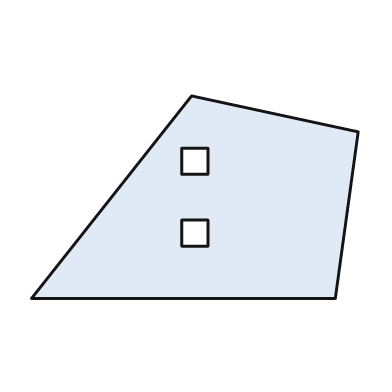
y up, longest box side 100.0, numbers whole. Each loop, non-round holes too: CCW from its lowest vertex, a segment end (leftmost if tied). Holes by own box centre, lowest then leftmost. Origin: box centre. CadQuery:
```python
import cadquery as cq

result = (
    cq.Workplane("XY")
    .moveTo(-50.0, -31.0)
    .lineTo(43.0, -31.0)
    .lineTo(50.0, 20.0)
    .lineTo(-1.0, 31.0)
    .close()
    .moveTo(-4.0, -15.0)
    .lineTo(4.0, -15.0)
    .lineTo(4.0, -7.0)
    .lineTo(-4.0, -7.0)
    .close()
    .moveTo(-4.0, 7.0)
    .lineTo(4.0, 7.0)
    .lineTo(4.0, 15.0)
    .lineTo(-4.0, 15.0)
    .close()
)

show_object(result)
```